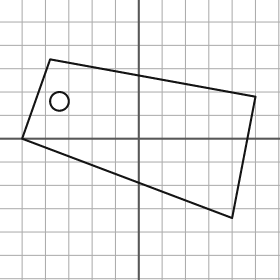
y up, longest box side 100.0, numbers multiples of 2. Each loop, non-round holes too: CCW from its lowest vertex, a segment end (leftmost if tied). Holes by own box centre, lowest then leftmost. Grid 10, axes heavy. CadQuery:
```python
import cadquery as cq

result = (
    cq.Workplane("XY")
    .moveTo(40.0, -34.0)
    .lineTo(50.0, 18.0)
    .lineTo(-38.0, 34.0)
    .lineTo(-50.0, 0.0)
    .close()
    .moveTo(-34.0, 16.0)
    .circle(4.0)
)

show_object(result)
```